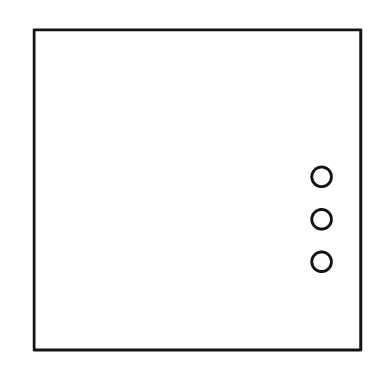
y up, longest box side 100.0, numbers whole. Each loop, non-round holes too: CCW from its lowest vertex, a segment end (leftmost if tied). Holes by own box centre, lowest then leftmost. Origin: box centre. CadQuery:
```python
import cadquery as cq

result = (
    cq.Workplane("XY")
    .moveTo(-50.0, -49.0)
    .lineTo(50.0, -49.0)
    .lineTo(50.0, 49.0)
    .lineTo(-50.0, 49.0)
    .close()
    .moveTo(38.0, -22.0)
    .circle(3.0)
    .moveTo(38.0, -9.0)
    .circle(3.0)
    .moveTo(38.0, 4.0)
    .circle(3.0)
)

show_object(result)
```